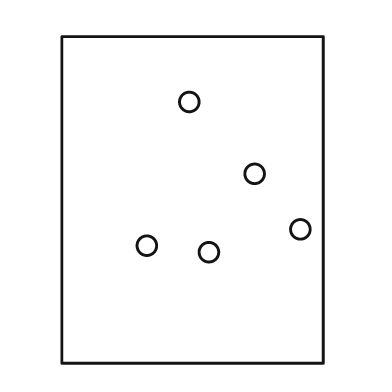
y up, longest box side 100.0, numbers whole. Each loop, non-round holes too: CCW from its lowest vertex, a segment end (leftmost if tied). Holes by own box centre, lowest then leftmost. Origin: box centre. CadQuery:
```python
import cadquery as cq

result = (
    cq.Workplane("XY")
    .moveTo(-40.0, -50.0)
    .lineTo(40.0, -50.0)
    .lineTo(40.0, 50.0)
    .lineTo(-40.0, 50.0)
    .close()
    .moveTo(5.0, -16.0)
    .circle(3.0)
    .moveTo(-14.0, -14.0)
    .circle(3.0)
    .moveTo(33.0, -9.0)
    .circle(3.0)
    .moveTo(19.0, 8.0)
    .circle(3.0)
    .moveTo(-1.0, 30.0)
    .circle(3.0)
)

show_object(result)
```